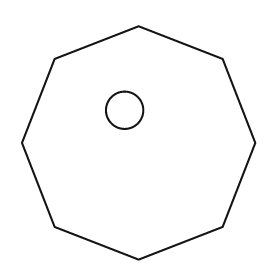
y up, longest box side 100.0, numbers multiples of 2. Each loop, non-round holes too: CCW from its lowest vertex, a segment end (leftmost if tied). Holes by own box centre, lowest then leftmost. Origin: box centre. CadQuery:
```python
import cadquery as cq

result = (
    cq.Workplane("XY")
    .moveTo(0.0, -50.0)
    .lineTo(36.0, -36.0)
    .lineTo(50.0, 0.0)
    .lineTo(36.0, 36.0)
    .lineTo(0.0, 50.0)
    .lineTo(-36.0, 36.0)
    .lineTo(-50.0, 0.0)
    .lineTo(-36.0, -36.0)
    .close()
    .moveTo(-6.0, 14.0)
    .circle(8.0)
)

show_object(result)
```